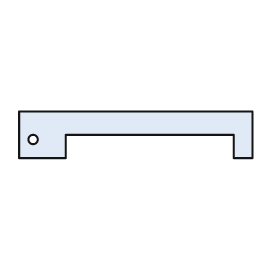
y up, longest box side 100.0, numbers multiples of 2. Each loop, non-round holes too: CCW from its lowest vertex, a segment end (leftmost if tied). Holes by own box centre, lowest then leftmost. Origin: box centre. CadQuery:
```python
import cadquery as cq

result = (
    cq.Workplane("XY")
    .moveTo(-50.0, -10.0)
    .lineTo(-30.0, -10.0)
    .lineTo(-30.0, 0.0)
    .lineTo(42.0, 0.0)
    .lineTo(42.0, -10.0)
    .lineTo(50.0, -10.0)
    .lineTo(50.0, 10.0)
    .lineTo(-50.0, 10.0)
    .close()
    .moveTo(-44.0, -2.0)
    .circle(2.0)
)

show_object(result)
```